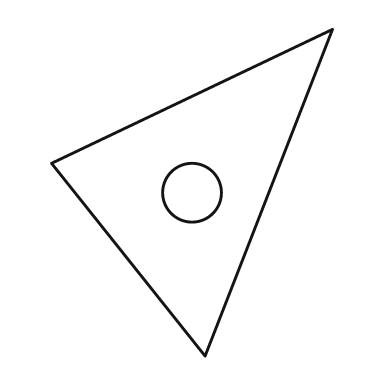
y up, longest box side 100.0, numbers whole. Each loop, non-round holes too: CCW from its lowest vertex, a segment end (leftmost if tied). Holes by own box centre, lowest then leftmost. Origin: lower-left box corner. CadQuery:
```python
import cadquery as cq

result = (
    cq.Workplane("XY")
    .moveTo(47.0, 0.0)
    .lineTo(86.0, 100.0)
    .lineTo(0.0, 59.0)
    .close()
    .moveTo(43.0, 50.0)
    .circle(9.0)
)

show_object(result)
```